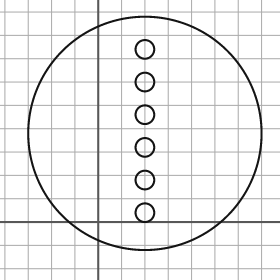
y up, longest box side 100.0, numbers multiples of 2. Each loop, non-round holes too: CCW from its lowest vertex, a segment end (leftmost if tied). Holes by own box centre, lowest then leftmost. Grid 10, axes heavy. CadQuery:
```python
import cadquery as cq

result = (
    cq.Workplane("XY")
    .moveTo(20.0, 38.0)
    .circle(50.0)
    .moveTo(20.0, 4.0)
    .circle(4.0)
    .moveTo(20.0, 18.0)
    .circle(4.0)
    .moveTo(20.0, 32.0)
    .circle(4.0)
    .moveTo(20.0, 46.0)
    .circle(4.0)
    .moveTo(20.0, 60.0)
    .circle(4.0)
    .moveTo(20.0, 74.0)
    .circle(4.0)
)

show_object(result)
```